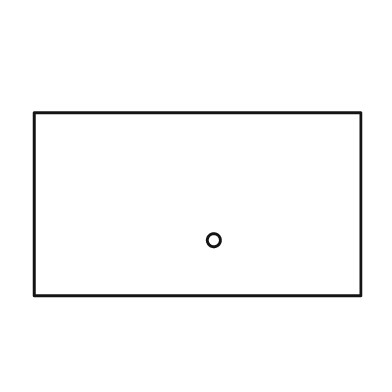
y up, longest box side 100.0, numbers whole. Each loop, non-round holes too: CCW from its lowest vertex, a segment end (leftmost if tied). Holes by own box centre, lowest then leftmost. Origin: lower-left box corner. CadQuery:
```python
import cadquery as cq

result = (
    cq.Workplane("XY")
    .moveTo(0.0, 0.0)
    .lineTo(100.0, 0.0)
    .lineTo(100.0, 56.0)
    .lineTo(0.0, 56.0)
    .close()
    .moveTo(55.0, 17.0)
    .circle(2.0)
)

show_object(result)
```